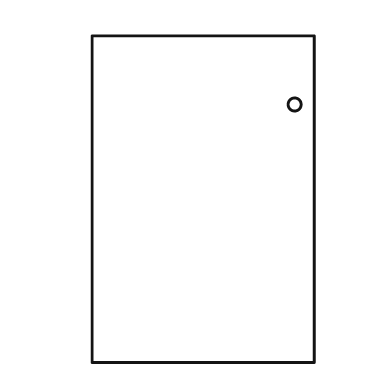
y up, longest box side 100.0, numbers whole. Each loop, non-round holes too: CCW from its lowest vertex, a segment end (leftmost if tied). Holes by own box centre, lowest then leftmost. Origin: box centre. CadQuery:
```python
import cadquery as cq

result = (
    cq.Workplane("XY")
    .moveTo(-34.0, -50.0)
    .lineTo(34.0, -50.0)
    .lineTo(34.0, 50.0)
    .lineTo(-34.0, 50.0)
    .close()
    .moveTo(28.0, 29.0)
    .circle(2.0)
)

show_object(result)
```